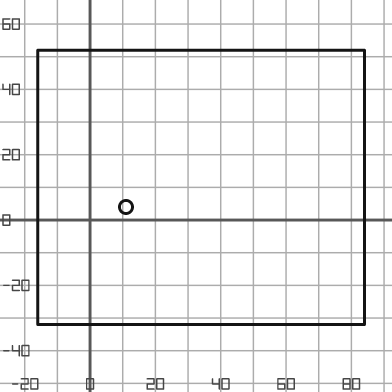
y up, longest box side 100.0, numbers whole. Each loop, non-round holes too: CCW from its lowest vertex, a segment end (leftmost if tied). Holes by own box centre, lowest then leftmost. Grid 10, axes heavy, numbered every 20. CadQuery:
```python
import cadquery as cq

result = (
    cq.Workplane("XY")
    .moveTo(-16.0, -32.0)
    .lineTo(84.0, -32.0)
    .lineTo(84.0, 52.0)
    .lineTo(-16.0, 52.0)
    .close()
    .moveTo(11.0, 4.0)
    .circle(2.0)
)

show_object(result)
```